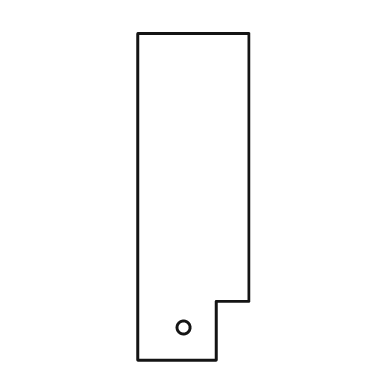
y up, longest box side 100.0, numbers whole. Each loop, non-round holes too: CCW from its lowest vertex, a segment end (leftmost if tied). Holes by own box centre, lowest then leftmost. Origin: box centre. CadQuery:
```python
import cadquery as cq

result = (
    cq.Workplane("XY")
    .moveTo(-17.0, -50.0)
    .lineTo(7.0, -50.0)
    .lineTo(7.0, -32.0)
    .lineTo(17.0, -32.0)
    .lineTo(17.0, 50.0)
    .lineTo(-17.0, 50.0)
    .close()
    .moveTo(-3.0, -40.0)
    .circle(2.0)
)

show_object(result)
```